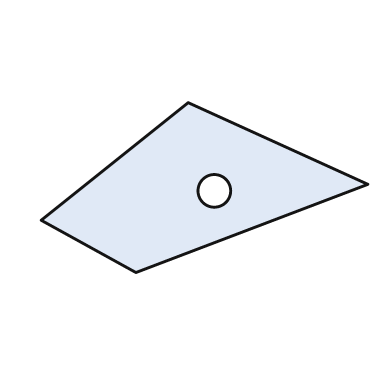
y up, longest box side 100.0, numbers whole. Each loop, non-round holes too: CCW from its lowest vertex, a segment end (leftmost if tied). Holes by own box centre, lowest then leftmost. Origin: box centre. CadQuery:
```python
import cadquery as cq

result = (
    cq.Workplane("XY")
    .moveTo(-21.0, -26.0)
    .lineTo(50.0, 1.0)
    .lineTo(-5.0, 26.0)
    .lineTo(-50.0, -10.0)
    .close()
    .moveTo(3.0, -1.0)
    .circle(5.0)
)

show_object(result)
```